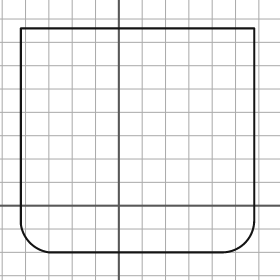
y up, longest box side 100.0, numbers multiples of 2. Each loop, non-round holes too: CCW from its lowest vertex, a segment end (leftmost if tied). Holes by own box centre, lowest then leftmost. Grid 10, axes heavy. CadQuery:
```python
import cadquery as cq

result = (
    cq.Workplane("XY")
    .moveTo(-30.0, -20.0)
    .lineTo(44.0, -20.0)
    .threePointArc((54.0, -16.0), (58.0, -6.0))
    .lineTo(58.0, 76.0)
    .lineTo(-42.0, 76.0)
    .lineTo(-42.0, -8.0)
    .threePointArc((-38.0, -16.0), (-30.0, -20.0))
    .close()
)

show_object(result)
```